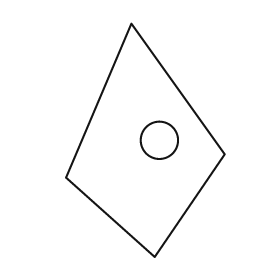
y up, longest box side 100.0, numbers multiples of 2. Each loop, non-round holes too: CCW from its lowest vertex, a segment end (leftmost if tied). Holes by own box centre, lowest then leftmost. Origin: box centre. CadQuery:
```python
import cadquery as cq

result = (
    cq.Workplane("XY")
    .moveTo(4.0, -50.0)
    .lineTo(34.0, -6.0)
    .lineTo(-6.0, 50.0)
    .lineTo(-34.0, -16.0)
    .close()
    .moveTo(6.0, 0.0)
    .circle(8.0)
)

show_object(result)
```